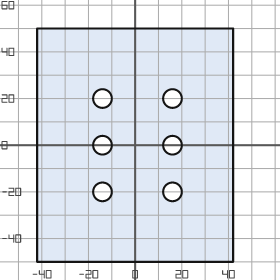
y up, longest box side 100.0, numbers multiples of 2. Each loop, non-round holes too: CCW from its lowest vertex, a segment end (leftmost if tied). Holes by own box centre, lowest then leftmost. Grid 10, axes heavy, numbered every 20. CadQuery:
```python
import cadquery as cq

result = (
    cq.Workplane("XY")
    .moveTo(-42.0, -50.0)
    .lineTo(42.0, -50.0)
    .lineTo(42.0, 50.0)
    .lineTo(-42.0, 50.0)
    .close()
    .moveTo(-14.0, -20.0)
    .circle(4.0)
    .moveTo(16.0, -20.0)
    .circle(4.0)
    .moveTo(-14.0, 0.0)
    .circle(4.0)
    .moveTo(16.0, 0.0)
    .circle(4.0)
    .moveTo(-14.0, 20.0)
    .circle(4.0)
    .moveTo(16.0, 20.0)
    .circle(4.0)
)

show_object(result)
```